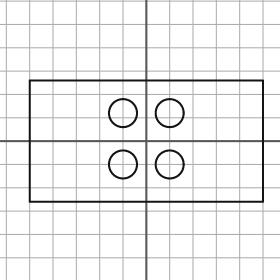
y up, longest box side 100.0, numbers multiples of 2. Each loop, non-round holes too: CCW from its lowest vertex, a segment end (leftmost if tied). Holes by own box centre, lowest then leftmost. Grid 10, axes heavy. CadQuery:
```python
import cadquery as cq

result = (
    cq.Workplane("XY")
    .moveTo(-50.0, -26.0)
    .lineTo(50.0, -26.0)
    .lineTo(50.0, 26.0)
    .lineTo(-50.0, 26.0)
    .close()
    .moveTo(-10.0, -10.0)
    .circle(6.0)
    .moveTo(10.0, -10.0)
    .circle(6.0)
    .moveTo(-10.0, 12.0)
    .circle(6.0)
    .moveTo(10.0, 12.0)
    .circle(6.0)
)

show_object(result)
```